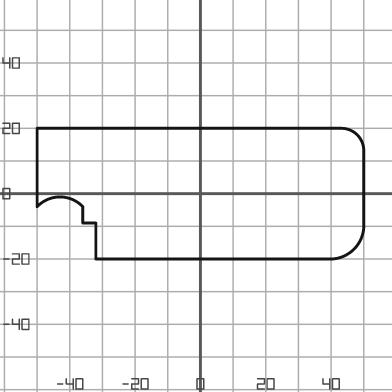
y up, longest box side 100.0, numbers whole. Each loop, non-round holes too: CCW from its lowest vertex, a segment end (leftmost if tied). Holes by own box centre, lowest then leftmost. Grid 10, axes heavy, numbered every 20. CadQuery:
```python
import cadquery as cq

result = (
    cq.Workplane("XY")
    .moveTo(-32.0, -20.0)
    .lineTo(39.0, -20.0)
    .threePointArc((47.0, -17.0), (50.0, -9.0))
    .lineTo(50.0, 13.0)
    .threePointArc((48.0, 18.0), (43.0, 20.0))
    .lineTo(-50.0, 20.0)
    .lineTo(-50.0, -4.0)
    .threePointArc((-43.0, -1.0), (-36.0, -4.0))
    .lineTo(-36.0, -9.0)
    .lineTo(-32.0, -9.0)
    .close()
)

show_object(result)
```